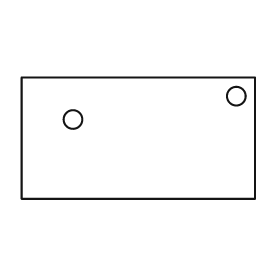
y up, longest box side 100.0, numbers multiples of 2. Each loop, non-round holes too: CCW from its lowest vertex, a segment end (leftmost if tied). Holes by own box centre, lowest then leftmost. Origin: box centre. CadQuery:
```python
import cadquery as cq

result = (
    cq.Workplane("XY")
    .moveTo(-50.0, -26.0)
    .lineTo(50.0, -26.0)
    .lineTo(50.0, 26.0)
    .lineTo(-50.0, 26.0)
    .close()
    .moveTo(-28.0, 8.0)
    .circle(4.0)
    .moveTo(42.0, 18.0)
    .circle(4.0)
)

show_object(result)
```